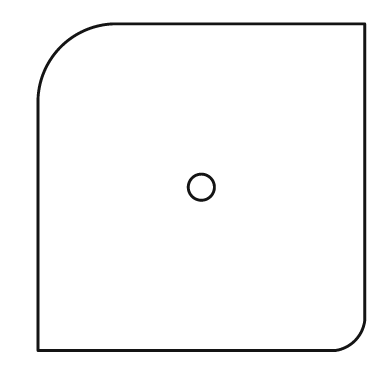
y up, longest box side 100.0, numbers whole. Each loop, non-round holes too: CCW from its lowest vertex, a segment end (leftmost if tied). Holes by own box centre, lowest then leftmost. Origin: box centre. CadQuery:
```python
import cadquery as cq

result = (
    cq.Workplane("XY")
    .moveTo(-50.0, -50.0)
    .lineTo(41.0, -50.0)
    .threePointArc((47.0, -47.0), (50.0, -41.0))
    .lineTo(50.0, 50.0)
    .lineTo(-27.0, 50.0)
    .threePointArc((-43.0, 43.0), (-50.0, 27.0))
    .close()
    .moveTo(0.0, 0.0)
    .circle(4.0)
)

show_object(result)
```